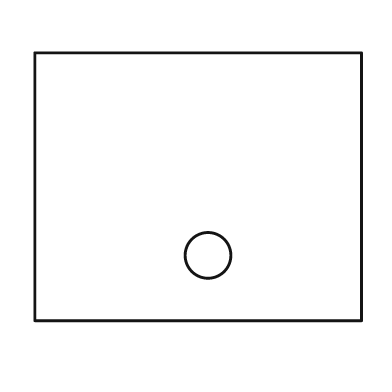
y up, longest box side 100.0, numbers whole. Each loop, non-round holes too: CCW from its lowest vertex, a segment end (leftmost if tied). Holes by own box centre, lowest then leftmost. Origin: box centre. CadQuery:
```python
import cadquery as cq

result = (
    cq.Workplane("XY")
    .moveTo(-50.0, -41.0)
    .lineTo(50.0, -41.0)
    .lineTo(50.0, 41.0)
    .lineTo(-50.0, 41.0)
    .close()
    .moveTo(3.0, -21.0)
    .circle(7.0)
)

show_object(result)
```